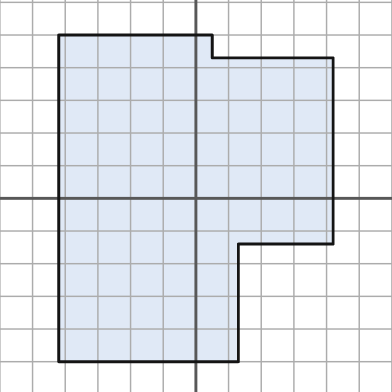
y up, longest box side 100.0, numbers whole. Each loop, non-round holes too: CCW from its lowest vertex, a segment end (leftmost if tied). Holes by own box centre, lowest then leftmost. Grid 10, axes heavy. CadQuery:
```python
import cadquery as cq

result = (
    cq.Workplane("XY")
    .moveTo(-42.0, -50.0)
    .lineTo(13.0, -50.0)
    .lineTo(13.0, -14.0)
    .lineTo(42.0, -14.0)
    .lineTo(42.0, 43.0)
    .lineTo(5.0, 43.0)
    .lineTo(5.0, 50.0)
    .lineTo(-42.0, 50.0)
    .close()
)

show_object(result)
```